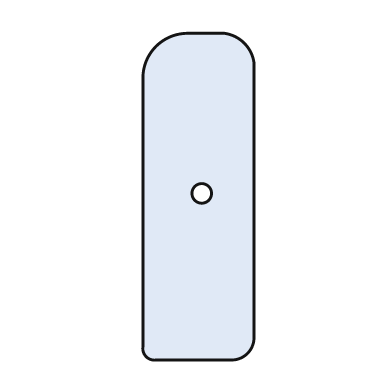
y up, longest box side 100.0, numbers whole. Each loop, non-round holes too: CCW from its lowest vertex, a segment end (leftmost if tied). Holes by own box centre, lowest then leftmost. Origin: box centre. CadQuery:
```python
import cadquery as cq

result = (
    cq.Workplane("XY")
    .moveTo(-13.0, -50.0)
    .lineTo(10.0, -50.0)
    .threePointArc((15.0, -48.0), (17.0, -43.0))
    .lineTo(17.0, 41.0)
    .threePointArc((14.0, 47.0), (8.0, 50.0))
    .lineTo(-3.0, 50.0)
    .threePointArc((-13.0, 46.0), (-17.0, 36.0))
    .lineTo(-17.0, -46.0)
    .threePointArc((-16.0, -49.0), (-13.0, -50.0))
    .close()
    .moveTo(1.0, 1.0)
    .circle(3.0)
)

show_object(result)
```